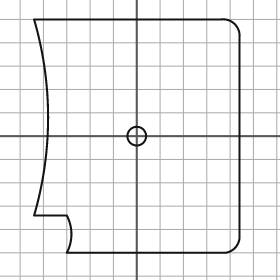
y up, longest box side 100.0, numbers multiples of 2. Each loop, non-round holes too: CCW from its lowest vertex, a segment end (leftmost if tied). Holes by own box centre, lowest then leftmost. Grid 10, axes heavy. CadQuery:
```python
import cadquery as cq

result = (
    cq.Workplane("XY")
    .moveTo(-30.0, -50.0)
    .lineTo(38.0, -50.0)
    .threePointArc((42.0, -48.0), (44.0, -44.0))
    .lineTo(44.0, 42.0)
    .threePointArc((42.0, 48.0), (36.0, 50.0))
    .lineTo(-44.0, 50.0)
    .threePointArc((-38.0, 8.0), (-44.0, -34.0))
    .lineTo(-30.0, -34.0)
    .threePointArc((-28.0, -42.0), (-30.0, -50.0))
    .close()
    .moveTo(0.0, 0.0)
    .circle(4.0)
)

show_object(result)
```